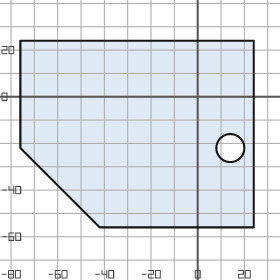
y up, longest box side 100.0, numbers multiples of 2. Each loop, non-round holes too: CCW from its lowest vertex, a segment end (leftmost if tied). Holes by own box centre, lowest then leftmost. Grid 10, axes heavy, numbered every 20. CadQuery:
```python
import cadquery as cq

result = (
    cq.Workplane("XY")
    .moveTo(-42.0, -56.0)
    .lineTo(24.0, -56.0)
    .lineTo(24.0, 24.0)
    .lineTo(-76.0, 24.0)
    .lineTo(-76.0, -22.0)
    .close()
    .moveTo(14.0, -22.0)
    .circle(6.0)
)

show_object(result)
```